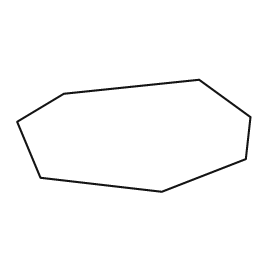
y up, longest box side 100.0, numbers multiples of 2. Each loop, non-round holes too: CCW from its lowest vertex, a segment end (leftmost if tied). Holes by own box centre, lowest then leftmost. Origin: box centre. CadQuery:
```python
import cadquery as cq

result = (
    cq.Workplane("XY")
    .moveTo(12.0, -24.0)
    .lineTo(48.0, -10.0)
    .lineTo(50.0, 8.0)
    .lineTo(28.0, 24.0)
    .lineTo(-30.0, 18.0)
    .lineTo(-50.0, 6.0)
    .lineTo(-40.0, -18.0)
    .close()
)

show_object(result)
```